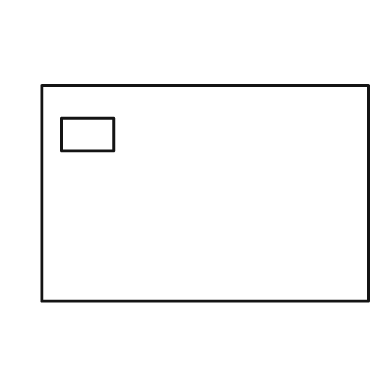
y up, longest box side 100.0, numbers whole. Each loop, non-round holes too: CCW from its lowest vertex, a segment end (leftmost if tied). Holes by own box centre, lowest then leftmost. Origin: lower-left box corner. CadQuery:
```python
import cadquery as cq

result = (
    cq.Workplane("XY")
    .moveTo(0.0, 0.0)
    .lineTo(100.0, 0.0)
    .lineTo(100.0, 66.0)
    .lineTo(0.0, 66.0)
    .close()
    .moveTo(6.0, 46.0)
    .lineTo(22.0, 46.0)
    .lineTo(22.0, 56.0)
    .lineTo(6.0, 56.0)
    .close()
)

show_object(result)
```